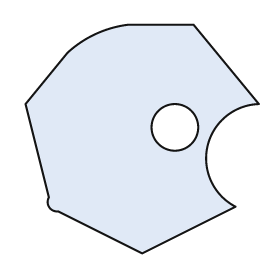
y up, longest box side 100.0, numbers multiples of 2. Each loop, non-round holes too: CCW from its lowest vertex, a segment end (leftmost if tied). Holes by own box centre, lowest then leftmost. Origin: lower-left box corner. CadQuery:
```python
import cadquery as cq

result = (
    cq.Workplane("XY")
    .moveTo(50.0, 0.0)
    .lineTo(90.0, 20.0)
    .threePointArc((78.0, 46.0), (100.0, 64.0))
    .lineTo(72.0, 98.0)
    .lineTo(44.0, 98.0)
    .threePointArc((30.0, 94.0), (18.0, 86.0))
    .lineTo(0.0, 64.0)
    .lineTo(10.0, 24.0)
    .threePointArc((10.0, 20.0), (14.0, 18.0))
    .close()
    .moveTo(64.0, 54.0)
    .circle(10.0)
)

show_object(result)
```